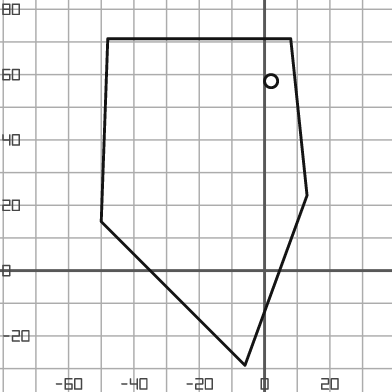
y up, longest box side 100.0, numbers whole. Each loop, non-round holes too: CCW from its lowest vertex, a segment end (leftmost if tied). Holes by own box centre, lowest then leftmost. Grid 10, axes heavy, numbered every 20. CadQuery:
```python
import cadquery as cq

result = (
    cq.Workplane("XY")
    .moveTo(-6.0, -29.0)
    .lineTo(13.0, 23.0)
    .lineTo(8.0, 71.0)
    .lineTo(-48.0, 71.0)
    .lineTo(-50.0, 15.0)
    .close()
    .moveTo(2.0, 58.0)
    .circle(2.0)
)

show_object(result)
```